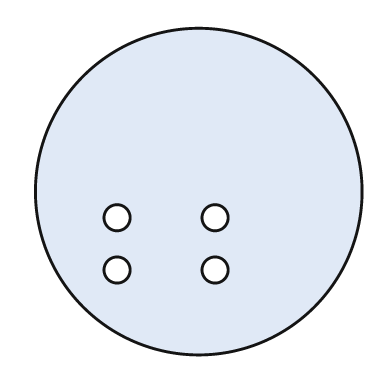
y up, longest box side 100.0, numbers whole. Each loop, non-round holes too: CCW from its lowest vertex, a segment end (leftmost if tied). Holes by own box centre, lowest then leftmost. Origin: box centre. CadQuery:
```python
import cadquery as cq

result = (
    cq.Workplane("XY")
    .moveTo(0.0, 0.0)
    .circle(50.0)
    .moveTo(-25.0, -24.0)
    .circle(4.0)
    .moveTo(5.0, -24.0)
    .circle(4.0)
    .moveTo(-25.0, -8.0)
    .circle(4.0)
    .moveTo(5.0, -8.0)
    .circle(4.0)
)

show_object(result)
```